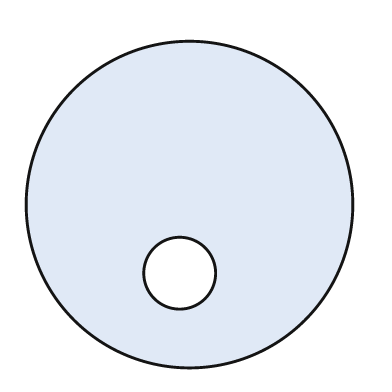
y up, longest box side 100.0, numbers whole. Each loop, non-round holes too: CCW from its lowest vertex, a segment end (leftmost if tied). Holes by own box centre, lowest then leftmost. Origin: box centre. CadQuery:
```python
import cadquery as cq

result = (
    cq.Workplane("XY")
    .moveTo(0.0, 0.0)
    .circle(50.0)
    .moveTo(-3.0, -21.0)
    .circle(11.0)
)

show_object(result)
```